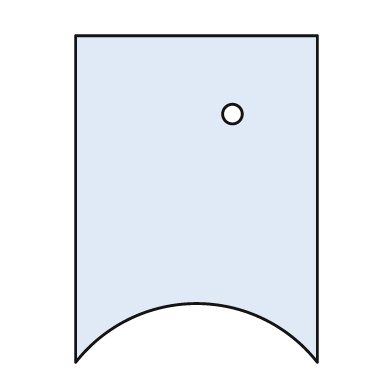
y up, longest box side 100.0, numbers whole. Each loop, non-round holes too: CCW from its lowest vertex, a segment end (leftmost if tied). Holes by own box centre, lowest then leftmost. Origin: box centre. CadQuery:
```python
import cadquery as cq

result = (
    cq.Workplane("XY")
    .moveTo(-37.0, -50.0)
    .threePointArc((0.0, -32.0), (37.0, -50.0))
    .lineTo(37.0, 50.0)
    .lineTo(-37.0, 50.0)
    .close()
    .moveTo(11.0, 26.0)
    .circle(3.0)
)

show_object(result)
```